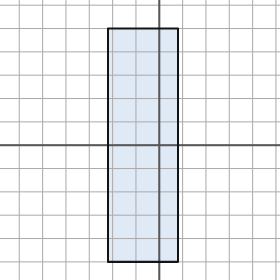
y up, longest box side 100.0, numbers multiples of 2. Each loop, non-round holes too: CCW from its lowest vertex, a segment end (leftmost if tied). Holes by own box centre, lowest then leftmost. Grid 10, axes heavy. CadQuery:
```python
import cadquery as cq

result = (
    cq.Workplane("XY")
    .moveTo(-22.0, -50.0)
    .lineTo(8.0, -50.0)
    .lineTo(8.0, 50.0)
    .lineTo(-22.0, 50.0)
    .close()
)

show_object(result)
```